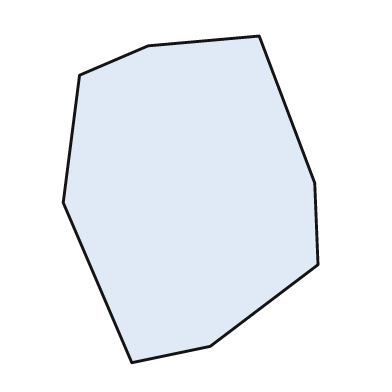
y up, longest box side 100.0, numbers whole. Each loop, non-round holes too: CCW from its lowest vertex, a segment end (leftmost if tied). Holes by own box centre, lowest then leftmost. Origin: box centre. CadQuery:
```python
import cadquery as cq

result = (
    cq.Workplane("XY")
    .moveTo(-18.0, -50.0)
    .lineTo(6.0, -45.0)
    .lineTo(39.0, -20.0)
    .lineTo(38.0, 5.0)
    .lineTo(21.0, 50.0)
    .lineTo(-13.0, 47.0)
    .lineTo(-34.0, 38.0)
    .lineTo(-39.0, -1.0)
    .close()
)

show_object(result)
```